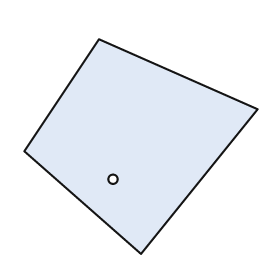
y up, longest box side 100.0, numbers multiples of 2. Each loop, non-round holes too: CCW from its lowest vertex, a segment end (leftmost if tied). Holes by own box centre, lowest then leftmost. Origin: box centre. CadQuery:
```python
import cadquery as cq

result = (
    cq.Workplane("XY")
    .moveTo(0.0, -46.0)
    .lineTo(50.0, 16.0)
    .lineTo(-18.0, 46.0)
    .lineTo(-50.0, -2.0)
    .close()
    .moveTo(-12.0, -14.0)
    .circle(2.0)
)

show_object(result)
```